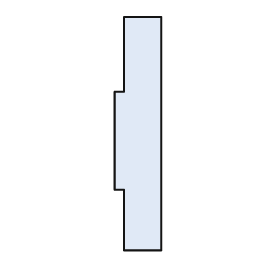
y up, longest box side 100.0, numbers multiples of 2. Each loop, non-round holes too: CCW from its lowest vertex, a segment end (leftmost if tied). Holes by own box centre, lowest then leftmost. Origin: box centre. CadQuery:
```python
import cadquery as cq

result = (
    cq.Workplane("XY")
    .moveTo(-6.0, -50.0)
    .lineTo(10.0, -50.0)
    .lineTo(10.0, 50.0)
    .lineTo(-6.0, 50.0)
    .lineTo(-6.0, 18.0)
    .lineTo(-10.0, 18.0)
    .lineTo(-10.0, -24.0)
    .lineTo(-6.0, -24.0)
    .close()
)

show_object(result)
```